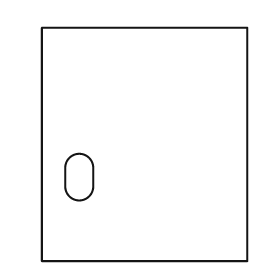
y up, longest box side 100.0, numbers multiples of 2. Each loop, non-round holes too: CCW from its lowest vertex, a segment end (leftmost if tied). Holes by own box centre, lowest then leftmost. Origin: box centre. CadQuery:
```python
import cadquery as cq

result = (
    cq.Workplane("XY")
    .moveTo(-44.0, -50.0)
    .lineTo(44.0, -50.0)
    .lineTo(44.0, 50.0)
    .lineTo(-44.0, 50.0)
    .close()
    .moveTo(-34.0, -18.0)
    .threePointArc((-28.0, -24.0), (-22.0, -18.0))
    .lineTo(-22.0, -10.0)
    .threePointArc((-28.0, -4.0), (-34.0, -10.0))
    .close()
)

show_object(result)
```